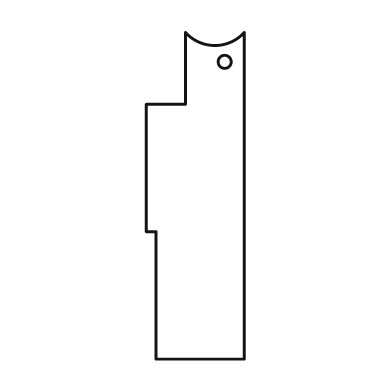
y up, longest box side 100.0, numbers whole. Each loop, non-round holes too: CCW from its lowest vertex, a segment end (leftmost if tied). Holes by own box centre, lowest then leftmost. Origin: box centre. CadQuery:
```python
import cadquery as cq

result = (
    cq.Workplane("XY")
    .moveTo(-12.0, -50.0)
    .lineTo(15.0, -50.0)
    .lineTo(15.0, 50.0)
    .threePointArc((6.0, 46.0), (-3.0, 50.0))
    .lineTo(-3.0, 28.0)
    .lineTo(-15.0, 28.0)
    .lineTo(-15.0, -11.0)
    .lineTo(-12.0, -11.0)
    .close()
    .moveTo(9.0, 41.0)
    .circle(2.0)
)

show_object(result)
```